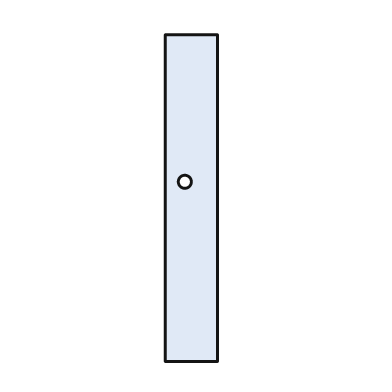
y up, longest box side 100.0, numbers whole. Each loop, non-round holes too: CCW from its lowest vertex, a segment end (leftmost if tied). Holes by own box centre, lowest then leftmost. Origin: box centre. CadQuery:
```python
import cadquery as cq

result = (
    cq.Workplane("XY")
    .moveTo(-8.0, -50.0)
    .lineTo(8.0, -50.0)
    .lineTo(8.0, 50.0)
    .lineTo(-8.0, 50.0)
    .close()
    .moveTo(-2.0, 5.0)
    .circle(2.0)
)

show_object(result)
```